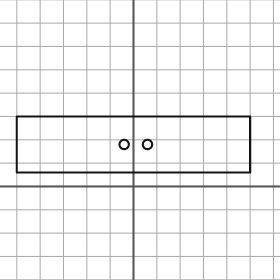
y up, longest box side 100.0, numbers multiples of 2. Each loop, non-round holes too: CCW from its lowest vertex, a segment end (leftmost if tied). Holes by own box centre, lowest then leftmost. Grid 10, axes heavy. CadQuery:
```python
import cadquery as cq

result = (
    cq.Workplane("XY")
    .moveTo(-50.0, 6.0)
    .lineTo(50.0, 6.0)
    .lineTo(50.0, 30.0)
    .lineTo(-50.0, 30.0)
    .close()
    .moveTo(-4.0, 18.0)
    .circle(2.0)
    .moveTo(6.0, 18.0)
    .circle(2.0)
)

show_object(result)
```